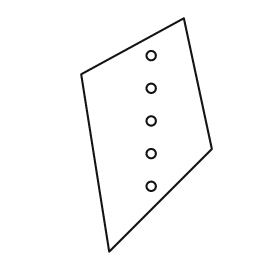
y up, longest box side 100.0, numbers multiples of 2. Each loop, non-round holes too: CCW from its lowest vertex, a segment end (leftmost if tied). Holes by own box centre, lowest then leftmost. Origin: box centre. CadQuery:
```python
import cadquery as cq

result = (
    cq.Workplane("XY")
    .moveTo(-16.0, -50.0)
    .lineTo(28.0, -6.0)
    .lineTo(16.0, 50.0)
    .lineTo(-28.0, 26.0)
    .close()
    .moveTo(2.0, -22.0)
    .circle(2.0)
    .moveTo(2.0, -8.0)
    .circle(2.0)
    .moveTo(2.0, 6.0)
    .circle(2.0)
    .moveTo(2.0, 20.0)
    .circle(2.0)
    .moveTo(2.0, 34.0)
    .circle(2.0)
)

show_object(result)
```